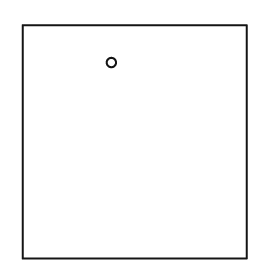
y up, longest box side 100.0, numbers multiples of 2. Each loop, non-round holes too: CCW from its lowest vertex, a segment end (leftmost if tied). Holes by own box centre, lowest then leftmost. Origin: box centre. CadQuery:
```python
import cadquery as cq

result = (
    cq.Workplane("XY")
    .moveTo(-48.0, -50.0)
    .lineTo(48.0, -50.0)
    .lineTo(48.0, 50.0)
    .lineTo(-48.0, 50.0)
    .close()
    .moveTo(-10.0, 34.0)
    .circle(2.0)
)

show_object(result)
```